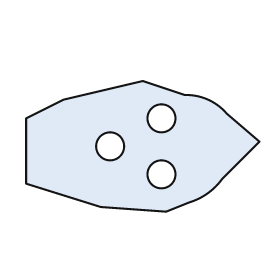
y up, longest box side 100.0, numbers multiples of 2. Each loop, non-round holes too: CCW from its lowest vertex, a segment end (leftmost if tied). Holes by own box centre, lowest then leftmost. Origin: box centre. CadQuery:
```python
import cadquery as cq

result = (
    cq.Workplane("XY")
    .moveTo(10.0, -28.0)
    .lineTo(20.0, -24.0)
    .threePointArc((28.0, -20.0), (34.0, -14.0))
    .lineTo(50.0, 2.0)
    .lineTo(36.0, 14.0)
    .threePointArc((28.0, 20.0), (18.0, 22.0))
    .lineTo(0.0, 28.0)
    .lineTo(-34.0, 20.0)
    .lineTo(-50.0, 12.0)
    .lineTo(-50.0, -16.0)
    .lineTo(-18.0, -26.0)
    .close()
    .moveTo(8.0, -12.0)
    .circle(6.0)
    .moveTo(-14.0, 0.0)
    .circle(6.0)
    .moveTo(8.0, 12.0)
    .circle(6.0)
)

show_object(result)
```